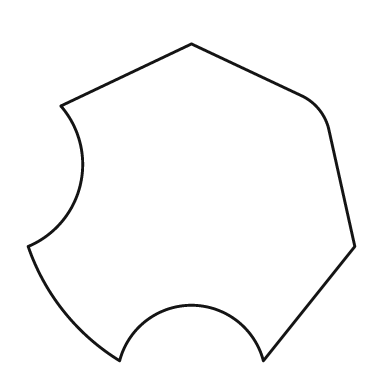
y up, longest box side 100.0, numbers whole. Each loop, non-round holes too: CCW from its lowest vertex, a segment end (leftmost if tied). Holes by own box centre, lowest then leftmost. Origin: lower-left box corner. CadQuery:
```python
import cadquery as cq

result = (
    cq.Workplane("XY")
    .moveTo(28.0, 0.0)
    .threePointArc((50.0, 17.0), (72.0, 0.0))
    .lineTo(100.0, 35.0)
    .lineTo(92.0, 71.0)
    .threePointArc((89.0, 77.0), (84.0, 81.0))
    .lineTo(50.0, 97.0)
    .lineTo(10.0, 78.0)
    .threePointArc((16.0, 54.0), (0.0, 35.0))
    .threePointArc((11.0, 15.0), (28.0, 0.0))
    .close()
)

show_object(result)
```